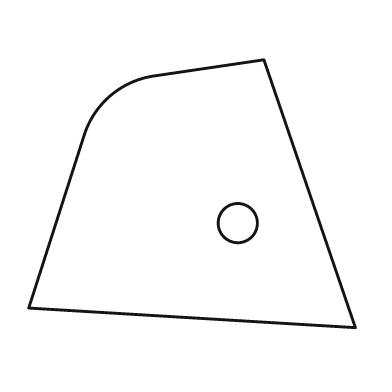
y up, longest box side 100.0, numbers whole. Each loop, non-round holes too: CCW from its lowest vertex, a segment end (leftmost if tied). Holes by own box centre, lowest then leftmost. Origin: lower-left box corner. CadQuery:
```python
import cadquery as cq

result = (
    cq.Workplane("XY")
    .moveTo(100.0, 0.0)
    .lineTo(72.0, 82.0)
    .lineTo(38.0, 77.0)
    .threePointArc((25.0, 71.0), (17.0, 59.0))
    .lineTo(0.0, 6.0)
    .close()
    .moveTo(64.0, 32.0)
    .circle(6.0)
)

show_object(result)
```